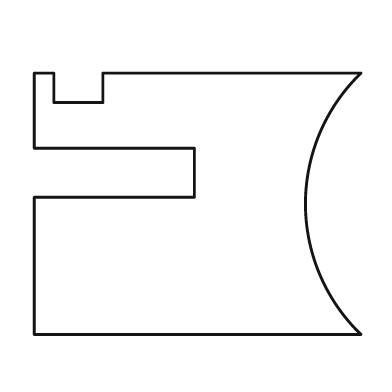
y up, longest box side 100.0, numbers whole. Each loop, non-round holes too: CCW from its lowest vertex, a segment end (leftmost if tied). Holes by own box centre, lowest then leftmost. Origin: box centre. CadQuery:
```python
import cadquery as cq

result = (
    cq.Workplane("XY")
    .moveTo(-50.0, -40.0)
    .lineTo(50.0, -40.0)
    .threePointArc((33.0, 0.0), (50.0, 40.0))
    .lineTo(-29.0, 40.0)
    .lineTo(-29.0, 31.0)
    .lineTo(-44.0, 31.0)
    .lineTo(-44.0, 40.0)
    .lineTo(-50.0, 40.0)
    .lineTo(-50.0, 17.0)
    .lineTo(-1.0, 17.0)
    .lineTo(-1.0, 2.0)
    .lineTo(-50.0, 2.0)
    .close()
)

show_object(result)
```